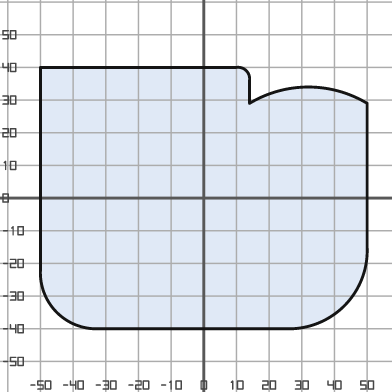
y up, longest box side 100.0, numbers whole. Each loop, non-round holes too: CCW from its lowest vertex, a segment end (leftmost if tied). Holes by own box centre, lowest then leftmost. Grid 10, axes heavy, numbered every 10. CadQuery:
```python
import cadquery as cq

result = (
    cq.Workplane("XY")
    .moveTo(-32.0, -40.0)
    .lineTo(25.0, -40.0)
    .threePointArc((43.0, -33.0), (50.0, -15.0))
    .lineTo(50.0, 29.0)
    .threePointArc((32.0, 34.0), (14.0, 29.0))
    .lineTo(14.0, 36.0)
    .threePointArc((13.0, 39.0), (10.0, 40.0))
    .lineTo(-50.0, 40.0)
    .lineTo(-50.0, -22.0)
    .threePointArc((-45.0, -35.0), (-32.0, -40.0))
    .close()
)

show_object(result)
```